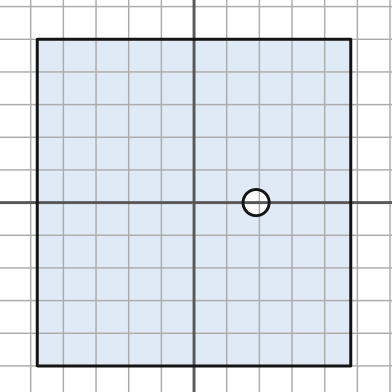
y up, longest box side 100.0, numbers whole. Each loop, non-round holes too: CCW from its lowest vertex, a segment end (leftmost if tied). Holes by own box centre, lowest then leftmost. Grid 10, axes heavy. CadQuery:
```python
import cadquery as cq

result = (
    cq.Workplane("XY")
    .moveTo(-48.0, -50.0)
    .lineTo(48.0, -50.0)
    .lineTo(48.0, 50.0)
    .lineTo(-48.0, 50.0)
    .close()
    .moveTo(19.0, 0.0)
    .circle(4.0)
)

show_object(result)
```